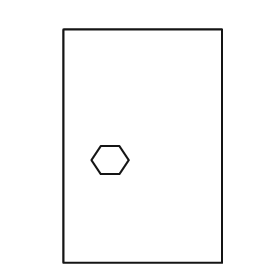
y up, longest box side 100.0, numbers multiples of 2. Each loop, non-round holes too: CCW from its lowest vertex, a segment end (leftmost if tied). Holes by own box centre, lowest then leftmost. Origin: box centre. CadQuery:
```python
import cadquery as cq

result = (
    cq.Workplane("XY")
    .moveTo(-34.0, -50.0)
    .lineTo(34.0, -50.0)
    .lineTo(34.0, 50.0)
    .lineTo(-34.0, 50.0)
    .close()
    .moveTo(-18.0, -12.0)
    .lineTo(-10.0, -12.0)
    .lineTo(-6.0, -6.0)
    .lineTo(-10.0, 0.0)
    .lineTo(-18.0, 0.0)
    .lineTo(-22.0, -6.0)
    .close()
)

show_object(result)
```